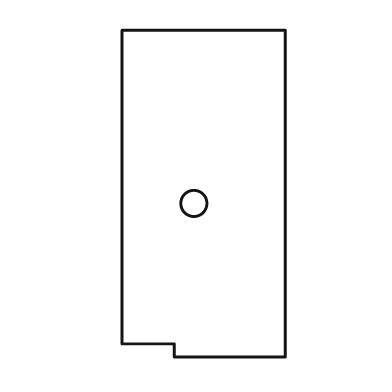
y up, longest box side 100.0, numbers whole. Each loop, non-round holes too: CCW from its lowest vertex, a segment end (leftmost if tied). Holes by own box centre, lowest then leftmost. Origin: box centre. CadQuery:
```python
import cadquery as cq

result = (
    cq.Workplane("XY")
    .moveTo(-9.0, -50.0)
    .lineTo(25.0, -50.0)
    .lineTo(25.0, 50.0)
    .lineTo(-25.0, 50.0)
    .lineTo(-25.0, -46.0)
    .lineTo(-9.0, -46.0)
    .close()
    .moveTo(-3.0, -3.0)
    .circle(4.0)
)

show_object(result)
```